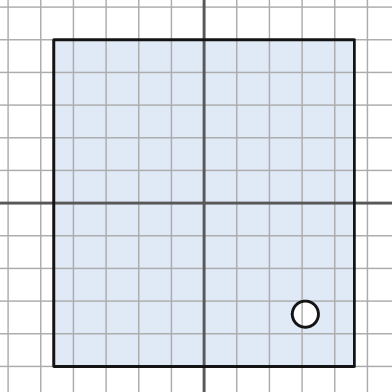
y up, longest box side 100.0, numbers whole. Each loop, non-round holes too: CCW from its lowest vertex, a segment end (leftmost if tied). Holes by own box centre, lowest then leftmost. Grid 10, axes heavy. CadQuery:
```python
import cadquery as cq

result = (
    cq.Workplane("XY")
    .moveTo(-46.0, -50.0)
    .lineTo(46.0, -50.0)
    .lineTo(46.0, 50.0)
    .lineTo(-46.0, 50.0)
    .close()
    .moveTo(31.0, -34.0)
    .circle(4.0)
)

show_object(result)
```